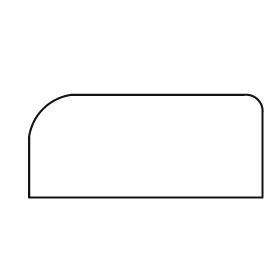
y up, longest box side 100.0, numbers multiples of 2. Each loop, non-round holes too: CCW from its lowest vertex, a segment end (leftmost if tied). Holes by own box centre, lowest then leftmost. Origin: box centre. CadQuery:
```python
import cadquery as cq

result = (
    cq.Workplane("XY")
    .moveTo(-50.0, -22.0)
    .lineTo(50.0, -22.0)
    .lineTo(50.0, 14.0)
    .threePointArc((48.0, 20.0), (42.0, 22.0))
    .lineTo(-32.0, 22.0)
    .threePointArc((-44.0, 16.0), (-50.0, 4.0))
    .close()
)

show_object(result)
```